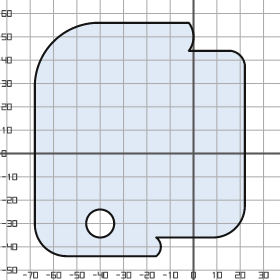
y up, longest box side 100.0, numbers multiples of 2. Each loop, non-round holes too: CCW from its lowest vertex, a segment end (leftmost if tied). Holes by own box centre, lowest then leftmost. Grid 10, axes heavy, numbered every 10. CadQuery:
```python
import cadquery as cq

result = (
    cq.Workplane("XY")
    .moveTo(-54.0, -44.0)
    .lineTo(-16.0, -44.0)
    .threePointArc((-14.0, -40.0), (-16.0, -36.0))
    .lineTo(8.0, -36.0)
    .threePointArc((18.0, -32.0), (22.0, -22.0))
    .lineTo(22.0, 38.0)
    .threePointArc((20.0, 42.0), (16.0, 44.0))
    .lineTo(-2.0, 44.0)
    .threePointArc((0.0, 50.0), (-2.0, 56.0))
    .lineTo(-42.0, 56.0)
    .threePointArc((-60.0, 48.0), (-68.0, 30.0))
    .lineTo(-68.0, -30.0)
    .threePointArc((-64.0, -40.0), (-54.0, -44.0))
    .close()
    .moveTo(-40.0, -30.0)
    .circle(6.0)
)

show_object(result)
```